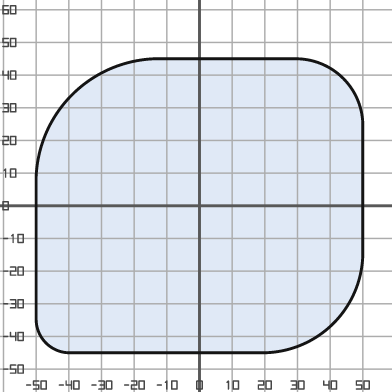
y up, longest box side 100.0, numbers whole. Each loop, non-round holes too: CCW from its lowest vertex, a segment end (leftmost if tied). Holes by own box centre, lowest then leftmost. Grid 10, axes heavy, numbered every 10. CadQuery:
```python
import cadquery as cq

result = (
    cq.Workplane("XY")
    .moveTo(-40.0, -45.0)
    .lineTo(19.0, -45.0)
    .threePointArc((41.0, -36.0), (50.0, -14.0))
    .lineTo(50.0, 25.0)
    .threePointArc((44.0, 39.0), (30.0, 45.0))
    .lineTo(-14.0, 45.0)
    .threePointArc((-39.0, 34.0), (-50.0, 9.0))
    .lineTo(-50.0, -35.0)
    .threePointArc((-47.0, -42.0), (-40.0, -45.0))
    .close()
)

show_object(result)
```